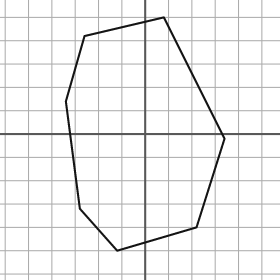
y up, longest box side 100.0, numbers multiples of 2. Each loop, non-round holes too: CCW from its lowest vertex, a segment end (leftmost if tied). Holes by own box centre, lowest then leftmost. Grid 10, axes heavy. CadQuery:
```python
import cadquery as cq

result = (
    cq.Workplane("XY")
    .moveTo(-12.0, -50.0)
    .lineTo(22.0, -40.0)
    .lineTo(34.0, -2.0)
    .lineTo(8.0, 50.0)
    .lineTo(-26.0, 42.0)
    .lineTo(-34.0, 14.0)
    .lineTo(-28.0, -32.0)
    .close()
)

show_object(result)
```